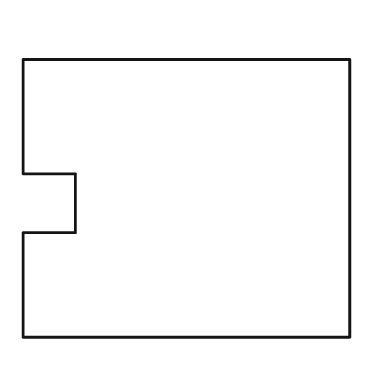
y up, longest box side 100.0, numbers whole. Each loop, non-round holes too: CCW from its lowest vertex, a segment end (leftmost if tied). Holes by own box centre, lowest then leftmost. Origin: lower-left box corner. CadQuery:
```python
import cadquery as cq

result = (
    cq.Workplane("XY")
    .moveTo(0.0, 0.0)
    .lineTo(100.0, 0.0)
    .lineTo(100.0, 85.0)
    .lineTo(0.0, 85.0)
    .lineTo(0.0, 50.0)
    .lineTo(16.0, 50.0)
    .lineTo(16.0, 32.0)
    .lineTo(0.0, 32.0)
    .close()
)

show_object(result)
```